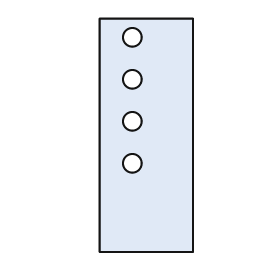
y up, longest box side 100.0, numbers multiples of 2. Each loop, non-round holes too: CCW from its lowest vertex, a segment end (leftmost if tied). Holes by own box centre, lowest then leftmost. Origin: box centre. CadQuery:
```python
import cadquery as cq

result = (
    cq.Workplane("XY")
    .moveTo(-20.0, -50.0)
    .lineTo(20.0, -50.0)
    .lineTo(20.0, 50.0)
    .lineTo(-20.0, 50.0)
    .close()
    .moveTo(-6.0, -12.0)
    .circle(4.0)
    .moveTo(-6.0, 6.0)
    .circle(4.0)
    .moveTo(-6.0, 24.0)
    .circle(4.0)
    .moveTo(-6.0, 42.0)
    .circle(4.0)
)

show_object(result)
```